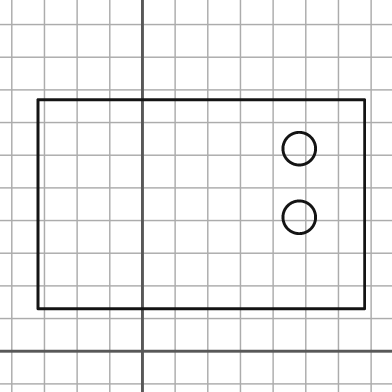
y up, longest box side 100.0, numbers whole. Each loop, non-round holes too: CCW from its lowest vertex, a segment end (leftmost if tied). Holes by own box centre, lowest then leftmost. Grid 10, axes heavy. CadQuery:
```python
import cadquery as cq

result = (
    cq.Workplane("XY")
    .moveTo(-32.0, 13.0)
    .lineTo(68.0, 13.0)
    .lineTo(68.0, 77.0)
    .lineTo(-32.0, 77.0)
    .close()
    .moveTo(48.0, 41.0)
    .circle(5.0)
    .moveTo(48.0, 62.0)
    .circle(5.0)
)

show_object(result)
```